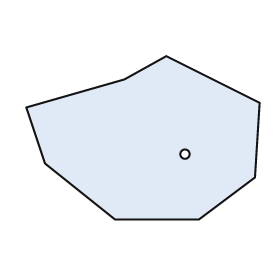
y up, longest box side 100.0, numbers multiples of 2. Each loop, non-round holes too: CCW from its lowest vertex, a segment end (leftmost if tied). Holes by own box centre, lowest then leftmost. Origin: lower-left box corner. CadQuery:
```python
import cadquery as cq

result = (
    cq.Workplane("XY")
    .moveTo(38.0, 0.0)
    .lineTo(74.0, 0.0)
    .lineTo(98.0, 18.0)
    .lineTo(100.0, 50.0)
    .lineTo(60.0, 70.0)
    .lineTo(42.0, 60.0)
    .lineTo(0.0, 48.0)
    .lineTo(8.0, 24.0)
    .close()
    .moveTo(68.0, 28.0)
    .circle(2.0)
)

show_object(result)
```